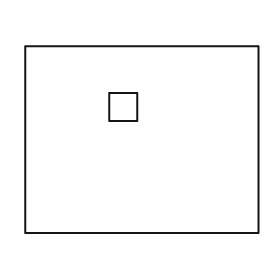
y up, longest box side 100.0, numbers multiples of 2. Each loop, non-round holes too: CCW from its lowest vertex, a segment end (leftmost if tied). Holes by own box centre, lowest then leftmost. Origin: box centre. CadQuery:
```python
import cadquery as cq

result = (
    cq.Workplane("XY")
    .moveTo(-50.0, -40.0)
    .lineTo(50.0, -40.0)
    .lineTo(50.0, 40.0)
    .lineTo(-50.0, 40.0)
    .close()
    .moveTo(-14.0, 8.0)
    .lineTo(-2.0, 8.0)
    .lineTo(-2.0, 20.0)
    .lineTo(-14.0, 20.0)
    .close()
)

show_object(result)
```